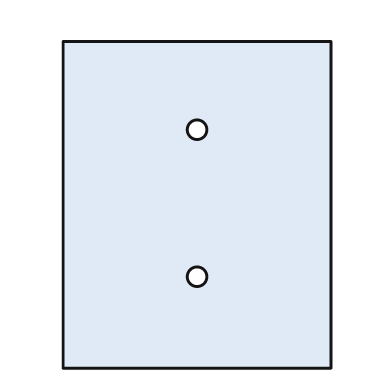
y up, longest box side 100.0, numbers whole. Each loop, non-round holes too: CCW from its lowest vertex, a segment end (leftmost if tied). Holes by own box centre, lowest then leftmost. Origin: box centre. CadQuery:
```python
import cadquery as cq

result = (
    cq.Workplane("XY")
    .moveTo(-41.0, -50.0)
    .lineTo(41.0, -50.0)
    .lineTo(41.0, 50.0)
    .lineTo(-41.0, 50.0)
    .close()
    .moveTo(0.0, -22.0)
    .circle(3.0)
    .moveTo(0.0, 23.0)
    .circle(3.0)
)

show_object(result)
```